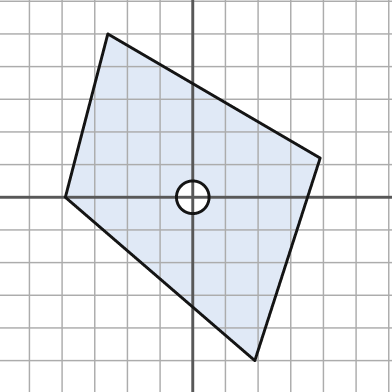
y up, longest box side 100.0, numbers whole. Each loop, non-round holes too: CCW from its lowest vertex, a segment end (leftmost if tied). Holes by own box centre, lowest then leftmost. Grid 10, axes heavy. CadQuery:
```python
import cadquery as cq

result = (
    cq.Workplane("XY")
    .moveTo(19.0, -50.0)
    .lineTo(39.0, 12.0)
    .lineTo(-26.0, 50.0)
    .lineTo(-39.0, 0.0)
    .close()
    .moveTo(0.0, 0.0)
    .circle(5.0)
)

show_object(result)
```